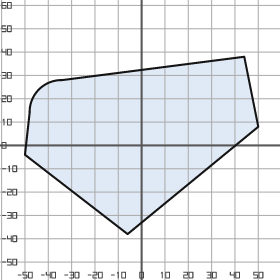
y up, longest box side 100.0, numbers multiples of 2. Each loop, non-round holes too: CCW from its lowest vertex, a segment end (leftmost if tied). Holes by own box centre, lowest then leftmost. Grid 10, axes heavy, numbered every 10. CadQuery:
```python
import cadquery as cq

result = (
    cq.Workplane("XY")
    .moveTo(-6.0, -38.0)
    .lineTo(50.0, 8.0)
    .lineTo(44.0, 38.0)
    .lineTo(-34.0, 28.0)
    .threePointArc((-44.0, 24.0), (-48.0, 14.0))
    .lineTo(-50.0, -4.0)
    .close()
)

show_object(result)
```